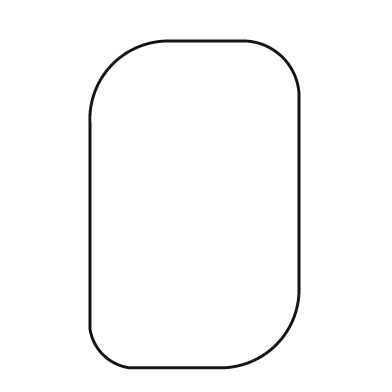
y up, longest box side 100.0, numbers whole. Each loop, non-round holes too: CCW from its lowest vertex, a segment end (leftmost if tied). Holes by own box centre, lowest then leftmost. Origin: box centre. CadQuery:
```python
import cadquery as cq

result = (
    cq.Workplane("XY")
    .moveTo(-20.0, -50.0)
    .lineTo(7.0, -50.0)
    .threePointArc((25.0, -43.0), (32.0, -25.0))
    .lineTo(32.0, 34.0)
    .threePointArc((27.0, 45.0), (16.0, 50.0))
    .lineTo(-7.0, 50.0)
    .threePointArc((-25.0, 43.0), (-32.0, 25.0))
    .lineTo(-32.0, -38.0)
    .threePointArc((-28.0, -46.0), (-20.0, -50.0))
    .close()
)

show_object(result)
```